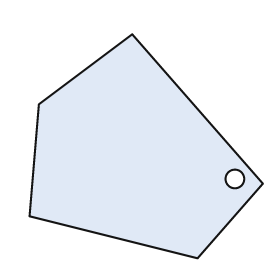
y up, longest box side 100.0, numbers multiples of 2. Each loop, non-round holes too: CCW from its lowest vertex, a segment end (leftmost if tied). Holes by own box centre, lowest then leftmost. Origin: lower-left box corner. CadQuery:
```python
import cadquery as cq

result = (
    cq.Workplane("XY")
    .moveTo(72.0, 0.0)
    .lineTo(100.0, 32.0)
    .lineTo(44.0, 96.0)
    .lineTo(4.0, 66.0)
    .lineTo(0.0, 18.0)
    .close()
    .moveTo(88.0, 34.0)
    .circle(4.0)
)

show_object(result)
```